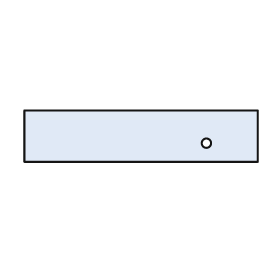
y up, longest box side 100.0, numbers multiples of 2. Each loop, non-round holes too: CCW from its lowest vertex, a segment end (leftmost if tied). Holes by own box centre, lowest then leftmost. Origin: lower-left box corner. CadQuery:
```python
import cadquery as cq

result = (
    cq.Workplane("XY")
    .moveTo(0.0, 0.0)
    .lineTo(100.0, 0.0)
    .lineTo(100.0, 22.0)
    .lineTo(0.0, 22.0)
    .close()
    .moveTo(78.0, 8.0)
    .circle(2.0)
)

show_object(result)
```